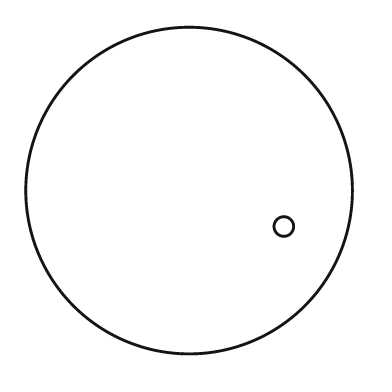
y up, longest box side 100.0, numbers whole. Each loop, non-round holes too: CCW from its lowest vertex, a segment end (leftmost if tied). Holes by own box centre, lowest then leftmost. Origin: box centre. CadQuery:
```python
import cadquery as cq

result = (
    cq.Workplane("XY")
    .moveTo(0.0, 0.0)
    .circle(50.0)
    .moveTo(29.0, -11.0)
    .circle(3.0)
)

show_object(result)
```